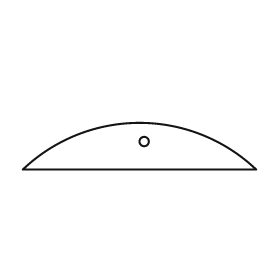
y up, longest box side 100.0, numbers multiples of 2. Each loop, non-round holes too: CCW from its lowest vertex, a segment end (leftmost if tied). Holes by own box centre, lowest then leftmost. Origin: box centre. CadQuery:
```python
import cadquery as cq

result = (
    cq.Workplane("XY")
    .moveTo(-50.0, -10.0)
    .lineTo(50.0, -10.0)
    .threePointArc((0.0, 10.0), (-50.0, -10.0))
    .close()
    .moveTo(2.0, 2.0)
    .circle(2.0)
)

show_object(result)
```